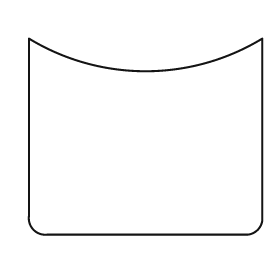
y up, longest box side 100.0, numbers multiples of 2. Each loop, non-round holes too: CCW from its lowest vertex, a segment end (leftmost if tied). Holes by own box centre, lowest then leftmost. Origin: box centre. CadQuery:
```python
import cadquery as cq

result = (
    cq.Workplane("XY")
    .moveTo(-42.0, -42.0)
    .lineTo(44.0, -42.0)
    .threePointArc((48.0, -40.0), (50.0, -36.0))
    .lineTo(50.0, 42.0)
    .threePointArc((0.0, 28.0), (-50.0, 42.0))
    .lineTo(-50.0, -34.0)
    .threePointArc((-48.0, -40.0), (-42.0, -42.0))
    .close()
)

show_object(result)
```